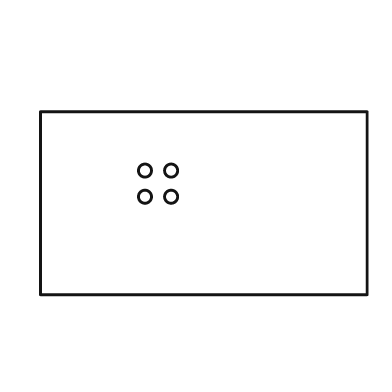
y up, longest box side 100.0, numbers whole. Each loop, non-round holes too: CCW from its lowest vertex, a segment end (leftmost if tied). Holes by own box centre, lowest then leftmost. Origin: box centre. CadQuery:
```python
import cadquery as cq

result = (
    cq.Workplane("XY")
    .moveTo(-50.0, -28.0)
    .lineTo(50.0, -28.0)
    .lineTo(50.0, 28.0)
    .lineTo(-50.0, 28.0)
    .close()
    .moveTo(-18.0, 2.0)
    .circle(2.0)
    .moveTo(-10.0, 2.0)
    .circle(2.0)
    .moveTo(-18.0, 10.0)
    .circle(2.0)
    .moveTo(-10.0, 10.0)
    .circle(2.0)
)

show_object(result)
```